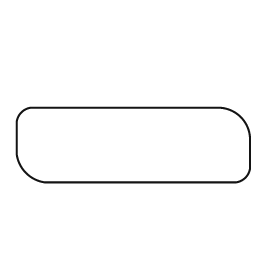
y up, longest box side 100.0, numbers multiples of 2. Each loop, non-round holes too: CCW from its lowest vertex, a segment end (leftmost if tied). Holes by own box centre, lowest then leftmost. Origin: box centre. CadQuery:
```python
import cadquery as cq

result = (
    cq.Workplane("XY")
    .moveTo(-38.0, -16.0)
    .lineTo(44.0, -16.0)
    .threePointArc((48.0, -14.0), (50.0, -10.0))
    .lineTo(50.0, 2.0)
    .threePointArc((46.0, 12.0), (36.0, 16.0))
    .lineTo(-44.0, 16.0)
    .threePointArc((-48.0, 14.0), (-50.0, 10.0))
    .lineTo(-50.0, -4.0)
    .threePointArc((-46.0, -12.0), (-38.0, -16.0))
    .close()
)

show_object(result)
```